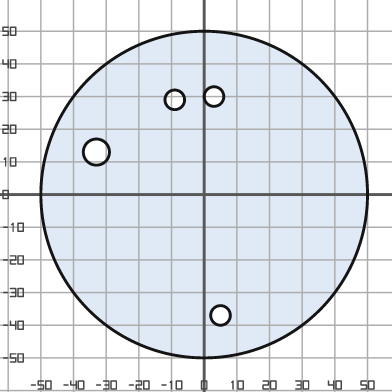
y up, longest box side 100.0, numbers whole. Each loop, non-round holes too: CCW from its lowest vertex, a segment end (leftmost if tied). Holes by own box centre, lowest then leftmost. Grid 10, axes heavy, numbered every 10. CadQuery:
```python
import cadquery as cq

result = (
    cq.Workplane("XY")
    .moveTo(0.0, 0.0)
    .circle(50.0)
    .moveTo(5.0, -37.0)
    .circle(3.0)
    .moveTo(-33.0, 13.0)
    .circle(4.0)
    .moveTo(-9.0, 29.0)
    .circle(3.0)
    .moveTo(3.0, 30.0)
    .circle(3.0)
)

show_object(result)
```